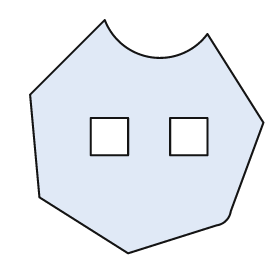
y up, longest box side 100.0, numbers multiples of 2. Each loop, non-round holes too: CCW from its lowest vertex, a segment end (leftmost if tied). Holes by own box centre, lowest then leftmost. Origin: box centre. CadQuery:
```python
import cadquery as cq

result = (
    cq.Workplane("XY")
    .moveTo(-8.0, -50.0)
    .lineTo(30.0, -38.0)
    .threePointArc((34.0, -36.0), (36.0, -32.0))
    .lineTo(50.0, 6.0)
    .lineTo(26.0, 44.0)
    .threePointArc((2.0, 34.0), (-18.0, 50.0))
    .lineTo(-50.0, 18.0)
    .lineTo(-46.0, -26.0)
    .close()
    .moveTo(-24.0, -8.0)
    .lineTo(-8.0, -8.0)
    .lineTo(-8.0, 8.0)
    .lineTo(-24.0, 8.0)
    .close()
    .moveTo(10.0, -8.0)
    .lineTo(26.0, -8.0)
    .lineTo(26.0, 8.0)
    .lineTo(10.0, 8.0)
    .close()
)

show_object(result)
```